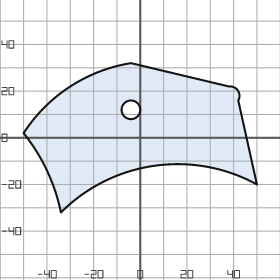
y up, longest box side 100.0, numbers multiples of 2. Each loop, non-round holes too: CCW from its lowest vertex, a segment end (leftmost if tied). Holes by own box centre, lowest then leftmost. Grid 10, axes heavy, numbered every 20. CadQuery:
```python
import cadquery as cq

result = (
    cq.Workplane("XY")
    .moveTo(-34.0, -32.0)
    .threePointArc((6.0, -12.0), (50.0, -20.0))
    .lineTo(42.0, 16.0)
    .threePointArc((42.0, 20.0), (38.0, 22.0))
    .lineTo(-4.0, 32.0)
    .threePointArc((-30.0, 22.0), (-50.0, 2.0))
    .threePointArc((-40.0, -14.0), (-34.0, -32.0))
    .close()
    .moveTo(-4.0, 12.0)
    .circle(4.0)
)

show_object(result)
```